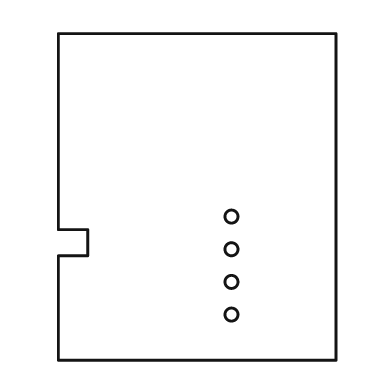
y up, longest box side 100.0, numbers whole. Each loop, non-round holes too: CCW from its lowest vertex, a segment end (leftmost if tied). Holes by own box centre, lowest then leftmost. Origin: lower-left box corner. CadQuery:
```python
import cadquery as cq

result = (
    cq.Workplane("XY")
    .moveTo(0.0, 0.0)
    .lineTo(85.0, 0.0)
    .lineTo(85.0, 100.0)
    .lineTo(0.0, 100.0)
    .lineTo(0.0, 40.0)
    .lineTo(9.0, 40.0)
    .lineTo(9.0, 32.0)
    .lineTo(0.0, 32.0)
    .close()
    .moveTo(53.0, 14.0)
    .circle(2.0)
    .moveTo(53.0, 24.0)
    .circle(2.0)
    .moveTo(53.0, 34.0)
    .circle(2.0)
    .moveTo(53.0, 44.0)
    .circle(2.0)
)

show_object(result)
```